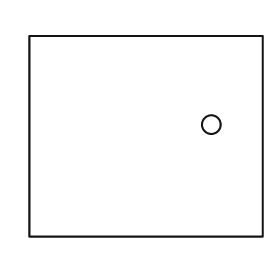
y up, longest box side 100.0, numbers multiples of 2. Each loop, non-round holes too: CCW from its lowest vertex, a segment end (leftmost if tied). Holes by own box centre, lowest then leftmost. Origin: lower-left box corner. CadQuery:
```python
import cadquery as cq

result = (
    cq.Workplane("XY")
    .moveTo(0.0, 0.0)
    .lineTo(100.0, 0.0)
    .lineTo(100.0, 86.0)
    .lineTo(0.0, 86.0)
    .close()
    .moveTo(78.0, 48.0)
    .circle(4.0)
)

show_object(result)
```